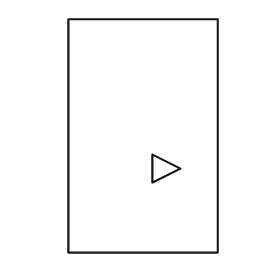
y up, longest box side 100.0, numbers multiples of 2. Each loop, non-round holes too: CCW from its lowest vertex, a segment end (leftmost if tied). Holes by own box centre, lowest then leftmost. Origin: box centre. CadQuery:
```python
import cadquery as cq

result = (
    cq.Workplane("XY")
    .moveTo(-32.0, -50.0)
    .lineTo(32.0, -50.0)
    .lineTo(32.0, 50.0)
    .lineTo(-32.0, 50.0)
    .close()
    .moveTo(4.0, -20.0)
    .lineTo(16.0, -14.0)
    .lineTo(4.0, -8.0)
    .close()
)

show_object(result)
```